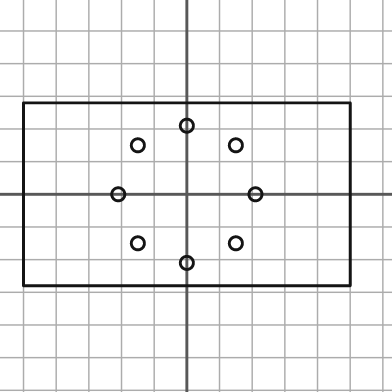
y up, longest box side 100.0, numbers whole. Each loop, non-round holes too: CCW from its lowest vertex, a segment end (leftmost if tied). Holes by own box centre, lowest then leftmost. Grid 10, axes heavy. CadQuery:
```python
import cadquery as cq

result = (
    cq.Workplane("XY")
    .moveTo(-50.0, -28.0)
    .lineTo(50.0, -28.0)
    .lineTo(50.0, 28.0)
    .lineTo(-50.0, 28.0)
    .close()
    .moveTo(0.0, -21.0)
    .circle(2.0)
    .moveTo(-15.0, -15.0)
    .circle(2.0)
    .moveTo(15.0, -15.0)
    .circle(2.0)
    .moveTo(-21.0, 0.0)
    .circle(2.0)
    .moveTo(21.0, 0.0)
    .circle(2.0)
    .moveTo(-15.0, 15.0)
    .circle(2.0)
    .moveTo(15.0, 15.0)
    .circle(2.0)
    .moveTo(0.0, 21.0)
    .circle(2.0)
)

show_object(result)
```